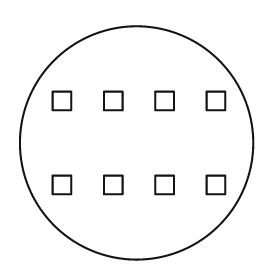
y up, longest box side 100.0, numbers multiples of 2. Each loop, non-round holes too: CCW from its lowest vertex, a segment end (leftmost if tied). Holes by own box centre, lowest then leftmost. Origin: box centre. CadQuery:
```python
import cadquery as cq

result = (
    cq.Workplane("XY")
    .moveTo(0.0, 0.0)
    .circle(50.0)
    .moveTo(-36.0, -22.0)
    .lineTo(-28.0, -22.0)
    .lineTo(-28.0, -14.0)
    .lineTo(-36.0, -14.0)
    .close()
    .moveTo(-14.0, -22.0)
    .lineTo(-6.0, -22.0)
    .lineTo(-6.0, -14.0)
    .lineTo(-14.0, -14.0)
    .close()
    .moveTo(8.0, -22.0)
    .lineTo(16.0, -22.0)
    .lineTo(16.0, -14.0)
    .lineTo(8.0, -14.0)
    .close()
    .moveTo(30.0, -22.0)
    .lineTo(38.0, -22.0)
    .lineTo(38.0, -14.0)
    .lineTo(30.0, -14.0)
    .close()
    .moveTo(-36.0, 14.0)
    .lineTo(-28.0, 14.0)
    .lineTo(-28.0, 22.0)
    .lineTo(-36.0, 22.0)
    .close()
    .moveTo(-14.0, 14.0)
    .lineTo(-6.0, 14.0)
    .lineTo(-6.0, 22.0)
    .lineTo(-14.0, 22.0)
    .close()
    .moveTo(8.0, 14.0)
    .lineTo(16.0, 14.0)
    .lineTo(16.0, 22.0)
    .lineTo(8.0, 22.0)
    .close()
    .moveTo(30.0, 14.0)
    .lineTo(38.0, 14.0)
    .lineTo(38.0, 22.0)
    .lineTo(30.0, 22.0)
    .close()
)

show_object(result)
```